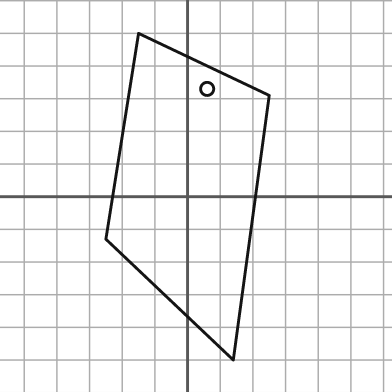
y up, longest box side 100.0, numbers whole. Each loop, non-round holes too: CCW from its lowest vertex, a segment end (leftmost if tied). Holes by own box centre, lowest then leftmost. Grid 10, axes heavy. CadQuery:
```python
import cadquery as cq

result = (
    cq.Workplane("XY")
    .moveTo(14.0, -50.0)
    .lineTo(25.0, 31.0)
    .lineTo(-15.0, 50.0)
    .lineTo(-25.0, -13.0)
    .close()
    .moveTo(6.0, 33.0)
    .circle(2.0)
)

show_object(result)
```